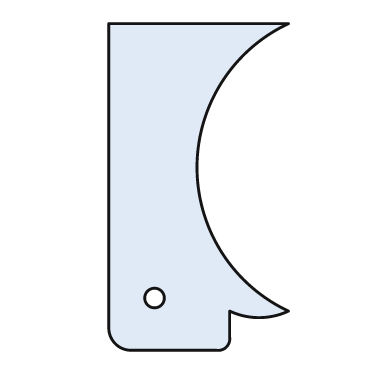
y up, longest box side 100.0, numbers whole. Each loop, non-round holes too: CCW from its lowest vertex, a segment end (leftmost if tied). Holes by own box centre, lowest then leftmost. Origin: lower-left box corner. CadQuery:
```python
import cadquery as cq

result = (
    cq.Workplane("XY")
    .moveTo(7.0, 0.0)
    .lineTo(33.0, 0.0)
    .threePointArc((36.0, 1.0), (37.0, 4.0))
    .lineTo(37.0, 12.0)
    .threePointArc((46.0, 10.0), (55.0, 12.0))
    .threePointArc((27.0, 56.0), (55.0, 100.0))
    .lineTo(0.0, 100.0)
    .lineTo(0.0, 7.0)
    .threePointArc((2.0, 2.0), (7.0, 0.0))
    .close()
    .moveTo(14.0, 16.0)
    .circle(3.0)
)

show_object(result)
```